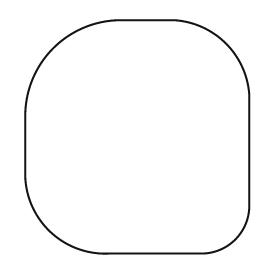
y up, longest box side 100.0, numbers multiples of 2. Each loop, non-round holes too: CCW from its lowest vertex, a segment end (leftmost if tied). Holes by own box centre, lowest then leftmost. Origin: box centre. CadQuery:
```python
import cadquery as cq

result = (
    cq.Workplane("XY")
    .moveTo(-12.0, -50.0)
    .lineTo(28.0, -50.0)
    .threePointArc((42.0, -44.0), (48.0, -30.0))
    .lineTo(48.0, 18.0)
    .threePointArc((38.0, 40.0), (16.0, 50.0))
    .lineTo(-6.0, 50.0)
    .threePointArc((-36.0, 38.0), (-48.0, 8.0))
    .lineTo(-48.0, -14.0)
    .threePointArc((-38.0, -40.0), (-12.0, -50.0))
    .close()
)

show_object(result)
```